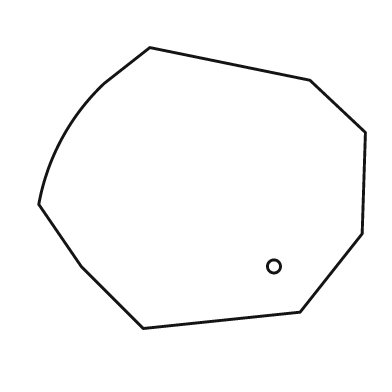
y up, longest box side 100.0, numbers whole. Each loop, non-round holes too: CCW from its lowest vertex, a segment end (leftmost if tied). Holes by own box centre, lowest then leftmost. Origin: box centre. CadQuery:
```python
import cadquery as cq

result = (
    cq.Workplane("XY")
    .moveTo(-18.0, -43.0)
    .lineTo(30.0, -38.0)
    .lineTo(49.0, -14.0)
    .lineTo(50.0, 17.0)
    .lineTo(33.0, 33.0)
    .lineTo(-16.0, 43.0)
    .lineTo(-30.0, 32.0)
    .threePointArc((-43.0, 15.0), (-50.0, -5.0))
    .lineTo(-37.0, -24.0)
    .close()
    .moveTo(22.0, -24.0)
    .circle(2.0)
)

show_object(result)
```